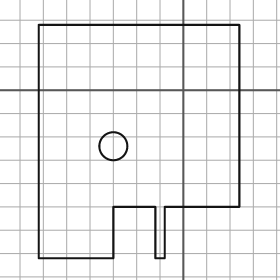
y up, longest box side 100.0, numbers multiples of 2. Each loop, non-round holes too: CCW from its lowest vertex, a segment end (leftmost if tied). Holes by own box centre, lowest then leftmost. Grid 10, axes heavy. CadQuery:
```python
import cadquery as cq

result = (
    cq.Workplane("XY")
    .moveTo(-62.0, -72.0)
    .lineTo(-30.0, -72.0)
    .lineTo(-30.0, -50.0)
    .lineTo(-12.0, -50.0)
    .lineTo(-12.0, -72.0)
    .lineTo(-8.0, -72.0)
    .lineTo(-8.0, -50.0)
    .lineTo(24.0, -50.0)
    .lineTo(24.0, 28.0)
    .lineTo(-62.0, 28.0)
    .close()
    .moveTo(-30.0, -24.0)
    .circle(6.0)
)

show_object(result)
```